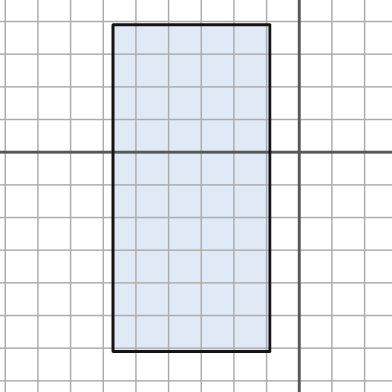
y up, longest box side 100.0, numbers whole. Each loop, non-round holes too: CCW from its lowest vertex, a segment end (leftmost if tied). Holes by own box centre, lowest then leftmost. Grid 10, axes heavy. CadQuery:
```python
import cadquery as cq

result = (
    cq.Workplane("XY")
    .moveTo(-57.0, -61.0)
    .lineTo(-9.0, -61.0)
    .lineTo(-9.0, 39.0)
    .lineTo(-57.0, 39.0)
    .close()
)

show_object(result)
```